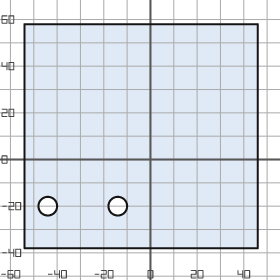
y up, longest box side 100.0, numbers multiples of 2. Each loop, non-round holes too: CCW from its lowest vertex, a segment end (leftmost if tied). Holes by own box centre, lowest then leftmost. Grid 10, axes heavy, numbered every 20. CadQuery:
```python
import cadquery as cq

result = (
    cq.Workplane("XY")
    .moveTo(-54.0, -38.0)
    .lineTo(46.0, -38.0)
    .lineTo(46.0, 58.0)
    .lineTo(-54.0, 58.0)
    .close()
    .moveTo(-44.0, -20.0)
    .circle(4.0)
    .moveTo(-14.0, -20.0)
    .circle(4.0)
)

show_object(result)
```